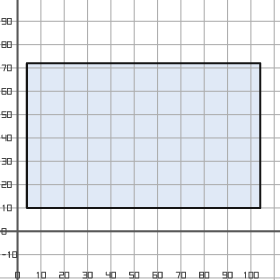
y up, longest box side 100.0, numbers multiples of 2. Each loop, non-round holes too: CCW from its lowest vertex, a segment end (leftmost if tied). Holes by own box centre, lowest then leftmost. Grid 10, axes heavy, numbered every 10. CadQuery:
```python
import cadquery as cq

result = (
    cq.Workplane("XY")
    .moveTo(4.0, 10.0)
    .lineTo(104.0, 10.0)
    .lineTo(104.0, 72.0)
    .lineTo(4.0, 72.0)
    .close()
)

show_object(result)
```